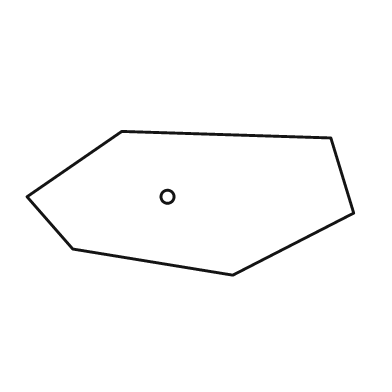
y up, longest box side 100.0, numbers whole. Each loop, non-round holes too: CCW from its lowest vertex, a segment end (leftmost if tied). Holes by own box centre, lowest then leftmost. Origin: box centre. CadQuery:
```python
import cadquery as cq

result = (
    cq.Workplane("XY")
    .moveTo(13.0, -22.0)
    .lineTo(50.0, -3.0)
    .lineTo(43.0, 20.0)
    .lineTo(-21.0, 22.0)
    .lineTo(-50.0, 2.0)
    .lineTo(-36.0, -14.0)
    .close()
    .moveTo(-7.0, 2.0)
    .circle(2.0)
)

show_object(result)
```